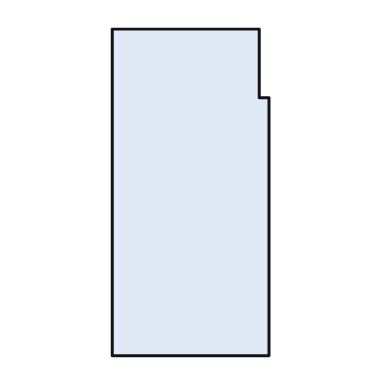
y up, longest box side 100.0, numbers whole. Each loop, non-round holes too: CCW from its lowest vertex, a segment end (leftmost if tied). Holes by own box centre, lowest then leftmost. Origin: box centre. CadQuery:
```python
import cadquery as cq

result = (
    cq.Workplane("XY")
    .moveTo(-24.0, -50.0)
    .lineTo(24.0, -50.0)
    .lineTo(24.0, 29.0)
    .lineTo(21.0, 29.0)
    .lineTo(21.0, 50.0)
    .lineTo(-24.0, 50.0)
    .close()
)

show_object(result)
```